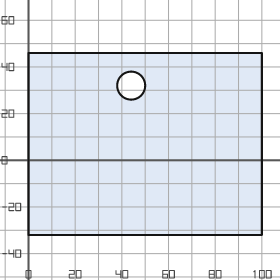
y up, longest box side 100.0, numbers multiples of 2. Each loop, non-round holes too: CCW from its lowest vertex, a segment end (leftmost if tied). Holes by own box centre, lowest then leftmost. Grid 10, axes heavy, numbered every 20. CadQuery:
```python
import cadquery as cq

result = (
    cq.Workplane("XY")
    .moveTo(0.0, -32.0)
    .lineTo(100.0, -32.0)
    .lineTo(100.0, 46.0)
    .lineTo(0.0, 46.0)
    .close()
    .moveTo(44.0, 32.0)
    .circle(6.0)
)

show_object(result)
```